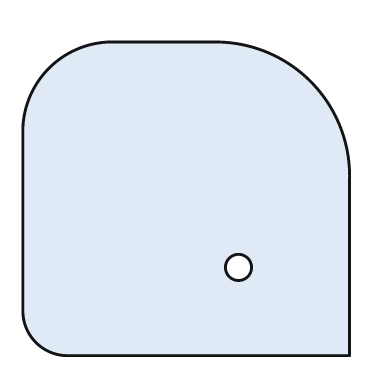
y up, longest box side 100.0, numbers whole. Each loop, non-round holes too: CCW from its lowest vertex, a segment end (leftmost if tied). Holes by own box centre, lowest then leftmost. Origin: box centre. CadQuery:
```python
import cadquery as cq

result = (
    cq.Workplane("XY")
    .moveTo(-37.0, -48.0)
    .lineTo(50.0, -48.0)
    .lineTo(50.0, 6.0)
    .threePointArc((38.0, 36.0), (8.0, 48.0))
    .lineTo(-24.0, 48.0)
    .threePointArc((-42.0, 40.0), (-50.0, 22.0))
    .lineTo(-50.0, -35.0)
    .threePointArc((-46.0, -44.0), (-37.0, -48.0))
    .close()
    .moveTo(16.0, -21.0)
    .circle(4.0)
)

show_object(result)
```